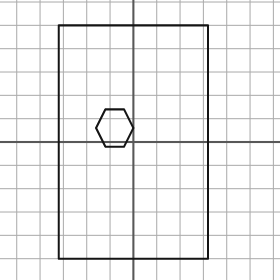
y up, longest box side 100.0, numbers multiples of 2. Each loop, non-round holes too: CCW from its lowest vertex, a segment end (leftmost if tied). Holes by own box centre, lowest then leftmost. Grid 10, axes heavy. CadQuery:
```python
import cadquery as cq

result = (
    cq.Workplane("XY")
    .moveTo(-32.0, -50.0)
    .lineTo(32.0, -50.0)
    .lineTo(32.0, 50.0)
    .lineTo(-32.0, 50.0)
    .close()
    .moveTo(-12.0, -2.0)
    .lineTo(-4.0, -2.0)
    .lineTo(0.0, 6.0)
    .lineTo(-4.0, 14.0)
    .lineTo(-12.0, 14.0)
    .lineTo(-16.0, 6.0)
    .close()
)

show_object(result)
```